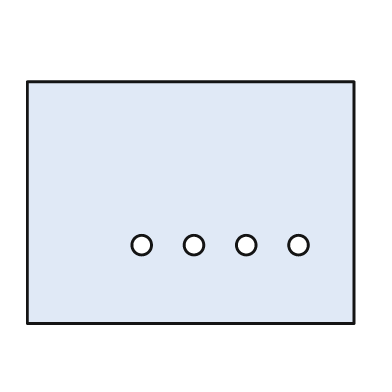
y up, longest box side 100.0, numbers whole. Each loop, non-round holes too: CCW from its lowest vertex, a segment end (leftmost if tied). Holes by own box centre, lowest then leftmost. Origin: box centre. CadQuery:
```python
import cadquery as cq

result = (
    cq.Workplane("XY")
    .moveTo(-50.0, -37.0)
    .lineTo(50.0, -37.0)
    .lineTo(50.0, 37.0)
    .lineTo(-50.0, 37.0)
    .close()
    .moveTo(-15.0, -13.0)
    .circle(3.0)
    .moveTo(1.0, -13.0)
    .circle(3.0)
    .moveTo(17.0, -13.0)
    .circle(3.0)
    .moveTo(33.0, -13.0)
    .circle(3.0)
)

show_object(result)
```